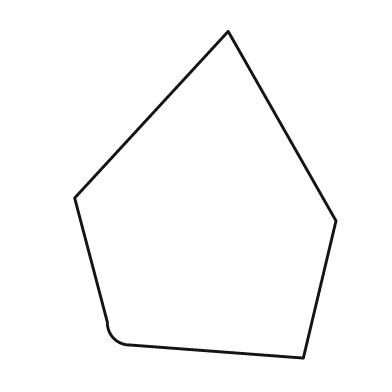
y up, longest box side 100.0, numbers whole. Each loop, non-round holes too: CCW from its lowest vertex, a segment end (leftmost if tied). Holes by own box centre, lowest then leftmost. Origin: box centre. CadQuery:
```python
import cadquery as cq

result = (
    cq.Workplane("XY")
    .moveTo(30.0, -50.0)
    .lineTo(40.0, -8.0)
    .lineTo(7.0, 50.0)
    .lineTo(-40.0, -1.0)
    .lineTo(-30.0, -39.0)
    .threePointArc((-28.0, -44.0), (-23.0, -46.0))
    .close()
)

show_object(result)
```